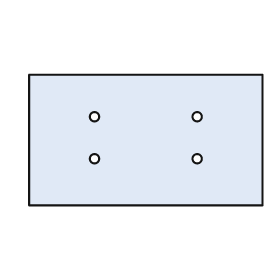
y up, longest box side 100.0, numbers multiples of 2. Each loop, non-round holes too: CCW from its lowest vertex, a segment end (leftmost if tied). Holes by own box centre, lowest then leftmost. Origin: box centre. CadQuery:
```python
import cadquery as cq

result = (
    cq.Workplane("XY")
    .moveTo(-50.0, -28.0)
    .lineTo(50.0, -28.0)
    .lineTo(50.0, 28.0)
    .lineTo(-50.0, 28.0)
    .close()
    .moveTo(-22.0, -8.0)
    .circle(2.0)
    .moveTo(22.0, -8.0)
    .circle(2.0)
    .moveTo(-22.0, 10.0)
    .circle(2.0)
    .moveTo(22.0, 10.0)
    .circle(2.0)
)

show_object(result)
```